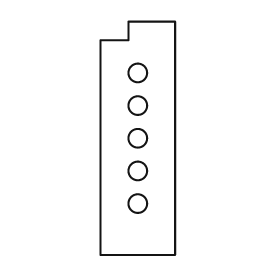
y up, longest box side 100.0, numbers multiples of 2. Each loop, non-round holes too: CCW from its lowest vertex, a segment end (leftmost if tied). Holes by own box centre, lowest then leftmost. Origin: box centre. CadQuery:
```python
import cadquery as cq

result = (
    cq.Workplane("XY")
    .moveTo(-16.0, -50.0)
    .lineTo(16.0, -50.0)
    .lineTo(16.0, 50.0)
    .lineTo(-4.0, 50.0)
    .lineTo(-4.0, 42.0)
    .lineTo(-16.0, 42.0)
    .close()
    .moveTo(0.0, -28.0)
    .circle(4.0)
    .moveTo(0.0, -14.0)
    .circle(4.0)
    .moveTo(0.0, 0.0)
    .circle(4.0)
    .moveTo(0.0, 14.0)
    .circle(4.0)
    .moveTo(0.0, 28.0)
    .circle(4.0)
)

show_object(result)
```